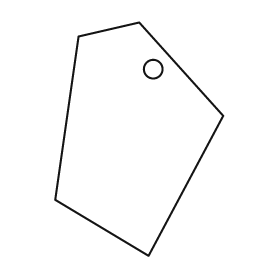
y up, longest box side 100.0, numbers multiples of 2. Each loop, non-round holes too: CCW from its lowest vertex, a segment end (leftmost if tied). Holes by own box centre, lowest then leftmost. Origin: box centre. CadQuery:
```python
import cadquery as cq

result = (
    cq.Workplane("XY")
    .moveTo(4.0, -50.0)
    .lineTo(36.0, 10.0)
    .lineTo(0.0, 50.0)
    .lineTo(-26.0, 44.0)
    .lineTo(-36.0, -26.0)
    .close()
    .moveTo(6.0, 30.0)
    .circle(4.0)
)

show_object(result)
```